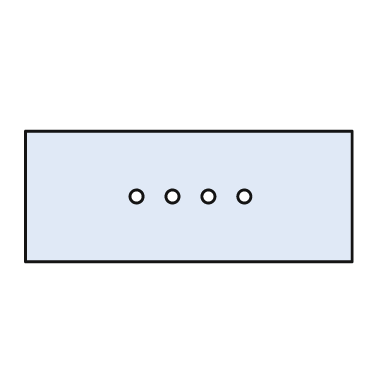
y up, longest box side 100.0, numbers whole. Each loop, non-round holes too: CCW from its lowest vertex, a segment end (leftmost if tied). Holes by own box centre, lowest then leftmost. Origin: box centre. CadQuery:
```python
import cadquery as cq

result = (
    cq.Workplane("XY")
    .moveTo(-50.0, -20.0)
    .lineTo(50.0, -20.0)
    .lineTo(50.0, 20.0)
    .lineTo(-50.0, 20.0)
    .close()
    .moveTo(-16.0, 0.0)
    .circle(2.0)
    .moveTo(-5.0, 0.0)
    .circle(2.0)
    .moveTo(6.0, 0.0)
    .circle(2.0)
    .moveTo(17.0, 0.0)
    .circle(2.0)
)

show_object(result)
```